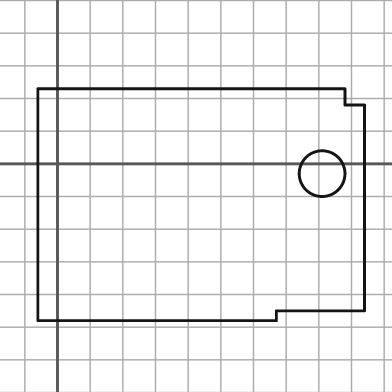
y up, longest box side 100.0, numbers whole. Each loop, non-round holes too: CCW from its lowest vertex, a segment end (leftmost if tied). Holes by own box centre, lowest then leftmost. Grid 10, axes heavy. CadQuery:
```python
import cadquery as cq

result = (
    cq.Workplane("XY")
    .moveTo(-6.0, -48.0)
    .lineTo(67.0, -48.0)
    .lineTo(67.0, -45.0)
    .lineTo(94.0, -45.0)
    .lineTo(94.0, 18.0)
    .lineTo(88.0, 18.0)
    .lineTo(88.0, 23.0)
    .lineTo(-6.0, 23.0)
    .close()
    .moveTo(81.0, -3.0)
    .circle(7.0)
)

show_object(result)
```